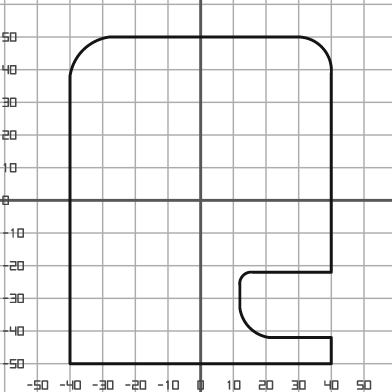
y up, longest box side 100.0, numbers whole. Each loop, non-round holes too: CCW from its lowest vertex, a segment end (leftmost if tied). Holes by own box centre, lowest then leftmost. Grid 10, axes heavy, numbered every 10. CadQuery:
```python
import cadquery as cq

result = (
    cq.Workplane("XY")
    .moveTo(-40.0, -50.0)
    .lineTo(40.0, -50.0)
    .lineTo(40.0, -42.0)
    .lineTo(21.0, -42.0)
    .threePointArc((15.0, -39.0), (12.0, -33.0))
    .lineTo(12.0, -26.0)
    .threePointArc((13.0, -23.0), (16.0, -22.0))
    .lineTo(40.0, -22.0)
    .lineTo(40.0, 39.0)
    .threePointArc((37.0, 47.0), (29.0, 50.0))
    .lineTo(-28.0, 50.0)
    .threePointArc((-36.0, 46.0), (-40.0, 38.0))
    .close()
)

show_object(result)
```